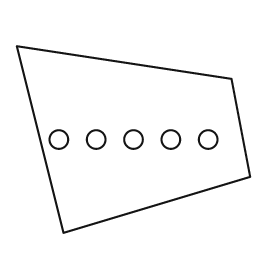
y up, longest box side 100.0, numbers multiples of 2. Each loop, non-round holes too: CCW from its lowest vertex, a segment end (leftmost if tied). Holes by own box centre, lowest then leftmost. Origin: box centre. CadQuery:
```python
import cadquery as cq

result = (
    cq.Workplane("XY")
    .moveTo(-30.0, -40.0)
    .lineTo(50.0, -16.0)
    .lineTo(42.0, 26.0)
    .lineTo(-50.0, 40.0)
    .close()
    .moveTo(-32.0, 0.0)
    .circle(4.0)
    .moveTo(-16.0, 0.0)
    .circle(4.0)
    .moveTo(0.0, 0.0)
    .circle(4.0)
    .moveTo(16.0, 0.0)
    .circle(4.0)
    .moveTo(32.0, 0.0)
    .circle(4.0)
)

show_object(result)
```